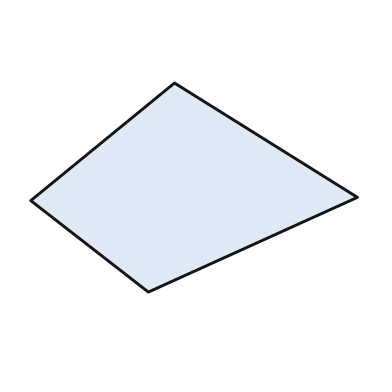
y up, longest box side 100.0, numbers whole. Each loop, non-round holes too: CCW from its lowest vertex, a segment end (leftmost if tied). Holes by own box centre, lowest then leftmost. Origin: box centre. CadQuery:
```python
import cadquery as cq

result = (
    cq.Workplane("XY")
    .moveTo(-14.0, -32.0)
    .lineTo(50.0, -3.0)
    .lineTo(-6.0, 32.0)
    .lineTo(-50.0, -4.0)
    .close()
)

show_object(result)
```